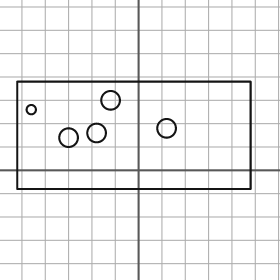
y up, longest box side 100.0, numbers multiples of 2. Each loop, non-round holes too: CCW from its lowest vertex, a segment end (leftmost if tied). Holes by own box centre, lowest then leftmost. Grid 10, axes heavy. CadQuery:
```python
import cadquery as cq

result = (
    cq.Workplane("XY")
    .moveTo(-52.0, -8.0)
    .lineTo(48.0, -8.0)
    .lineTo(48.0, 38.0)
    .lineTo(-52.0, 38.0)
    .close()
    .moveTo(-30.0, 14.0)
    .circle(4.0)
    .moveTo(-18.0, 16.0)
    .circle(4.0)
    .moveTo(12.0, 18.0)
    .circle(4.0)
    .moveTo(-46.0, 26.0)
    .circle(2.0)
    .moveTo(-12.0, 30.0)
    .circle(4.0)
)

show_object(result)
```